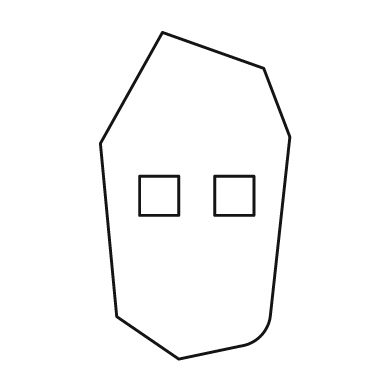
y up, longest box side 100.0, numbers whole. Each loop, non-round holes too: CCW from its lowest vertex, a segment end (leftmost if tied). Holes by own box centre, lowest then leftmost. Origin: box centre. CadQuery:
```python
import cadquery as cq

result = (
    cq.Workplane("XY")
    .moveTo(-5.0, -50.0)
    .lineTo(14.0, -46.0)
    .threePointArc((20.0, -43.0), (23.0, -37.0))
    .lineTo(29.0, 18.0)
    .lineTo(21.0, 39.0)
    .lineTo(-10.0, 50.0)
    .lineTo(-29.0, 16.0)
    .lineTo(-24.0, -37.0)
    .close()
    .moveTo(-17.0, -6.0)
    .lineTo(-5.0, -6.0)
    .lineTo(-5.0, 6.0)
    .lineTo(-17.0, 6.0)
    .close()
    .moveTo(6.0, -6.0)
    .lineTo(18.0, -6.0)
    .lineTo(18.0, 6.0)
    .lineTo(6.0, 6.0)
    .close()
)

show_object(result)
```